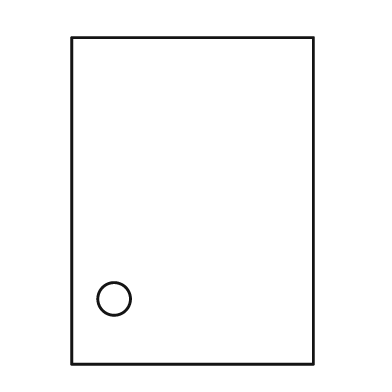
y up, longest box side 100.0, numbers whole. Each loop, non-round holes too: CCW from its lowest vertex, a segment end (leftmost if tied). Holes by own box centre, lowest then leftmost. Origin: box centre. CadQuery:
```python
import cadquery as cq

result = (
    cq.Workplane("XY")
    .moveTo(-37.0, -50.0)
    .lineTo(37.0, -50.0)
    .lineTo(37.0, 50.0)
    .lineTo(-37.0, 50.0)
    .close()
    .moveTo(-24.0, -30.0)
    .circle(5.0)
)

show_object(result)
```